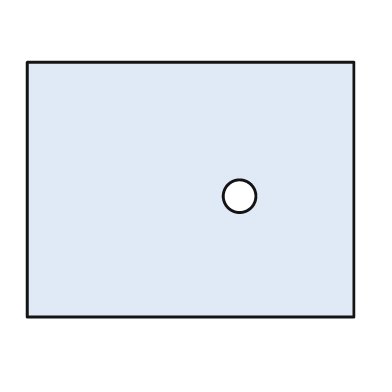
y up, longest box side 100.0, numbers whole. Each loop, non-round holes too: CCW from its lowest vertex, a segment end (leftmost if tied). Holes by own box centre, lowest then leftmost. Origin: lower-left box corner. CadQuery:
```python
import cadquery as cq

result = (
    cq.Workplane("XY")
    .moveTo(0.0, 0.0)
    .lineTo(100.0, 0.0)
    .lineTo(100.0, 78.0)
    .lineTo(0.0, 78.0)
    .close()
    .moveTo(65.0, 37.0)
    .circle(5.0)
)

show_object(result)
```